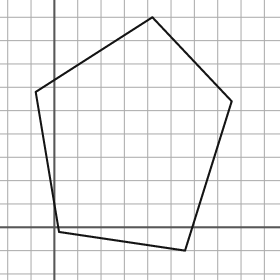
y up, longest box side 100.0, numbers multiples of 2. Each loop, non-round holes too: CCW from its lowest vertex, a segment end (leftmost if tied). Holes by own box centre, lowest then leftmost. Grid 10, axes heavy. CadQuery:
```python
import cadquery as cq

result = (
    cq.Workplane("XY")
    .moveTo(56.0, -10.0)
    .lineTo(76.0, 54.0)
    .lineTo(42.0, 90.0)
    .lineTo(-8.0, 58.0)
    .lineTo(2.0, -2.0)
    .close()
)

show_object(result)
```